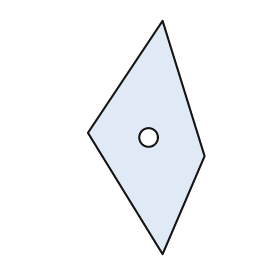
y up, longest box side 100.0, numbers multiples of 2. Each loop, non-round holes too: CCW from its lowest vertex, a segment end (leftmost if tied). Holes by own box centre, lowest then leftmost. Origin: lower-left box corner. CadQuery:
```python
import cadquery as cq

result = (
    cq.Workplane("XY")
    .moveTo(32.0, 0.0)
    .lineTo(50.0, 42.0)
    .lineTo(32.0, 100.0)
    .lineTo(0.0, 52.0)
    .close()
    .moveTo(26.0, 50.0)
    .circle(4.0)
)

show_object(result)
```